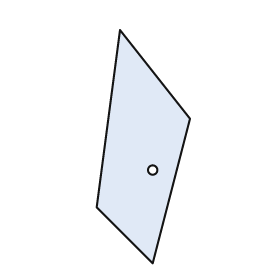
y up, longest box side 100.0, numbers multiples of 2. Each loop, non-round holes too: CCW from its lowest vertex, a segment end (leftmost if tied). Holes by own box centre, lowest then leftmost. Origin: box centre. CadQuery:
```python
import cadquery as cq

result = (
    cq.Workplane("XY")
    .moveTo(4.0, -50.0)
    .lineTo(20.0, 12.0)
    .lineTo(-10.0, 50.0)
    .lineTo(-20.0, -26.0)
    .close()
    .moveTo(4.0, -10.0)
    .circle(2.0)
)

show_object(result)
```